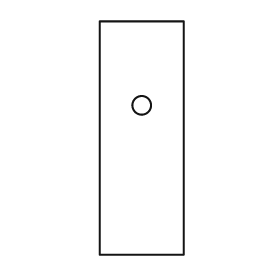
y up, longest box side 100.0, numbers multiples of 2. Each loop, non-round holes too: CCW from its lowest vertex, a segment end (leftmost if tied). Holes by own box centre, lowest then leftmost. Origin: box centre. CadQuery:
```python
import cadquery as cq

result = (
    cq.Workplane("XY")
    .moveTo(-18.0, -50.0)
    .lineTo(18.0, -50.0)
    .lineTo(18.0, 50.0)
    .lineTo(-18.0, 50.0)
    .close()
    .moveTo(0.0, 14.0)
    .circle(4.0)
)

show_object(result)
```